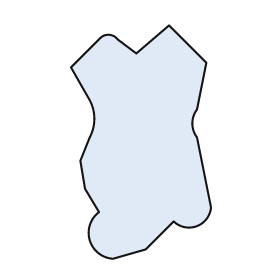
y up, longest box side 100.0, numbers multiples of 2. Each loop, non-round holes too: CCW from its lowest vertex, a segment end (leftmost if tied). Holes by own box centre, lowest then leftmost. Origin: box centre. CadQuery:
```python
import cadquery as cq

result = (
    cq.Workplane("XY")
    .moveTo(-12.0, -50.0)
    .lineTo(2.0, -46.0)
    .lineTo(14.0, -34.0)
    .threePointArc((24.0, -36.0), (30.0, -28.0))
    .lineTo(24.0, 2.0)
    .threePointArc((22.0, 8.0), (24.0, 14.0))
    .lineTo(28.0, 34.0)
    .lineTo(12.0, 50.0)
    .lineTo(-2.0, 38.0)
    .lineTo(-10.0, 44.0)
    .threePointArc((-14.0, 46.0), (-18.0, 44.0))
    .lineTo(-30.0, 32.0)
    .lineTo(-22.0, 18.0)
    .threePointArc((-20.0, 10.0), (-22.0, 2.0))
    .lineTo(-26.0, -8.0)
    .lineTo(-24.0, -20.0)
    .lineTo(-18.0, -30.0)
    .threePointArc((-22.0, -42.0), (-12.0, -50.0))
    .close()
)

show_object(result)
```